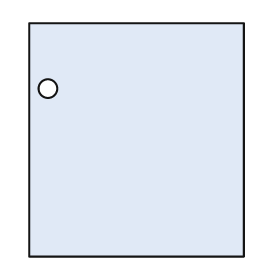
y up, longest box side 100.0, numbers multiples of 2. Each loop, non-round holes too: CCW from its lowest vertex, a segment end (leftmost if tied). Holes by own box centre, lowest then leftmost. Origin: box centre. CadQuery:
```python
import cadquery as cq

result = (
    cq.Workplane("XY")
    .moveTo(-46.0, -50.0)
    .lineTo(46.0, -50.0)
    .lineTo(46.0, 50.0)
    .lineTo(-46.0, 50.0)
    .close()
    .moveTo(-38.0, 22.0)
    .circle(4.0)
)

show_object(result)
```